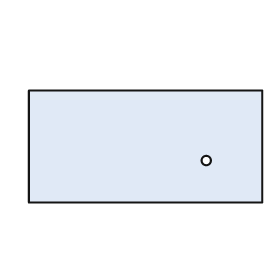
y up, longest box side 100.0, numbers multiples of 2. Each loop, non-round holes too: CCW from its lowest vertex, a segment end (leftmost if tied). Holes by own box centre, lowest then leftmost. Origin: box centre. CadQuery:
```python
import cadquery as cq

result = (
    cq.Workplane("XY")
    .moveTo(-50.0, -24.0)
    .lineTo(50.0, -24.0)
    .lineTo(50.0, 24.0)
    .lineTo(-50.0, 24.0)
    .close()
    .moveTo(26.0, -6.0)
    .circle(2.0)
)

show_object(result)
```